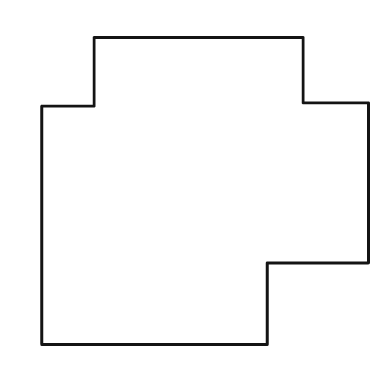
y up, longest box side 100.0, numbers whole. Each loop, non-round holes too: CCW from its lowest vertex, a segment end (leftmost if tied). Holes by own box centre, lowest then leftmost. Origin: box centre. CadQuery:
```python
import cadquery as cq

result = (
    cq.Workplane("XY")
    .moveTo(-50.0, -47.0)
    .lineTo(19.0, -47.0)
    .lineTo(19.0, -22.0)
    .lineTo(50.0, -22.0)
    .lineTo(50.0, 27.0)
    .lineTo(30.0, 27.0)
    .lineTo(30.0, 47.0)
    .lineTo(-34.0, 47.0)
    .lineTo(-34.0, 26.0)
    .lineTo(-50.0, 26.0)
    .close()
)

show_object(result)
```